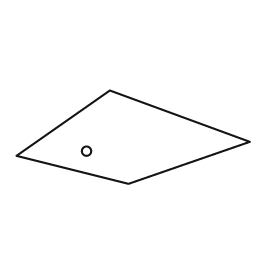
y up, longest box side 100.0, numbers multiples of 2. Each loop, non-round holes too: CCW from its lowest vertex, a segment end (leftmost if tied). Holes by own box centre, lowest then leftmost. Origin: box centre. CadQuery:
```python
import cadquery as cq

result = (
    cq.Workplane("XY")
    .moveTo(-2.0, -20.0)
    .lineTo(50.0, -2.0)
    .lineTo(-10.0, 20.0)
    .lineTo(-50.0, -8.0)
    .close()
    .moveTo(-20.0, -6.0)
    .circle(2.0)
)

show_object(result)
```